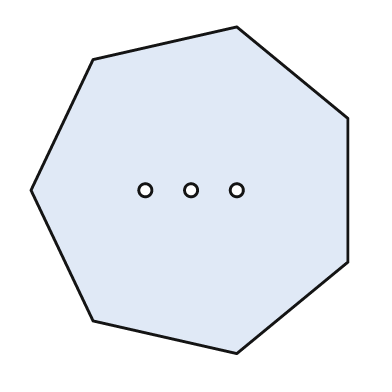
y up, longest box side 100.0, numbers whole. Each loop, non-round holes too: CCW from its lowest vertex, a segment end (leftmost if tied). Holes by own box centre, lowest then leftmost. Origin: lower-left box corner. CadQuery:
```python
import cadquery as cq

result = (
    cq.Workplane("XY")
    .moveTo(63.0, 0.0)
    .lineTo(97.0, 28.0)
    .lineTo(97.0, 72.0)
    .lineTo(63.0, 100.0)
    .lineTo(19.0, 90.0)
    .lineTo(0.0, 50.0)
    .lineTo(19.0, 10.0)
    .close()
    .moveTo(35.0, 50.0)
    .circle(2.0)
    .moveTo(49.0, 50.0)
    .circle(2.0)
    .moveTo(63.0, 50.0)
    .circle(2.0)
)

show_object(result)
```